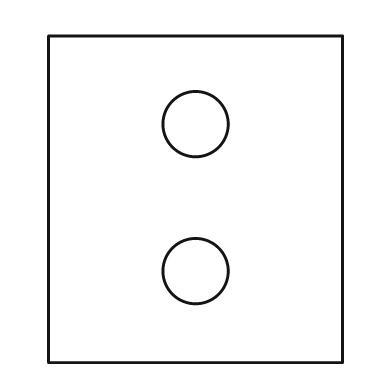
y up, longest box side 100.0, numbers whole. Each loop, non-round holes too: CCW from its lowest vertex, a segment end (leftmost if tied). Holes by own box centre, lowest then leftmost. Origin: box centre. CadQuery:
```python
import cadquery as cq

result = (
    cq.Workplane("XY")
    .moveTo(-45.0, -50.0)
    .lineTo(45.0, -50.0)
    .lineTo(45.0, 50.0)
    .lineTo(-45.0, 50.0)
    .close()
    .moveTo(0.0, -22.0)
    .circle(10.0)
    .moveTo(0.0, 23.0)
    .circle(10.0)
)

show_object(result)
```